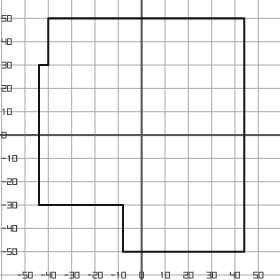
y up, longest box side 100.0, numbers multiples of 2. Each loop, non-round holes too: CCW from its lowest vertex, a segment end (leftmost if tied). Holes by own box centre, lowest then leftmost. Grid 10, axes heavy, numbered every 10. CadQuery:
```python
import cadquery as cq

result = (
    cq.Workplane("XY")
    .moveTo(-8.0, -50.0)
    .lineTo(44.0, -50.0)
    .lineTo(44.0, 50.0)
    .lineTo(-40.0, 50.0)
    .lineTo(-40.0, 30.0)
    .lineTo(-44.0, 30.0)
    .lineTo(-44.0, -30.0)
    .lineTo(-8.0, -30.0)
    .close()
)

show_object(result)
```